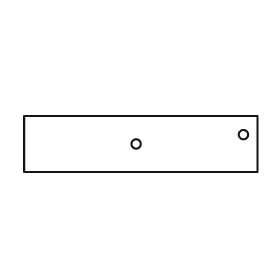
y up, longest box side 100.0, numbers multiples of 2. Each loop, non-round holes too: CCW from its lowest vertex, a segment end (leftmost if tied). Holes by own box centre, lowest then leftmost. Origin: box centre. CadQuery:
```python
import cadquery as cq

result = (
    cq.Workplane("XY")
    .moveTo(-50.0, -12.0)
    .lineTo(50.0, -12.0)
    .lineTo(50.0, 12.0)
    .lineTo(-50.0, 12.0)
    .close()
    .moveTo(-2.0, 0.0)
    .circle(2.0)
    .moveTo(44.0, 4.0)
    .circle(2.0)
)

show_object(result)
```